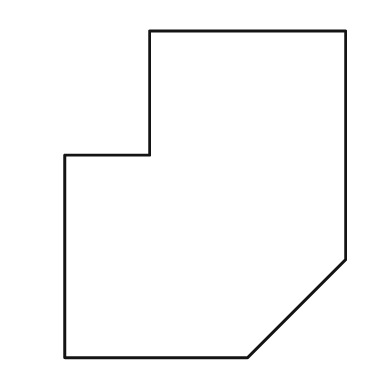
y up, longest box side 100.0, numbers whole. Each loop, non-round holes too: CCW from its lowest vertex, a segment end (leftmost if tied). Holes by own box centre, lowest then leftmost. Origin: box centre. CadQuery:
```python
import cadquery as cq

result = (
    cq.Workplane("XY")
    .moveTo(-43.0, -50.0)
    .lineTo(13.0, -50.0)
    .lineTo(43.0, -20.0)
    .lineTo(43.0, 50.0)
    .lineTo(-17.0, 50.0)
    .lineTo(-17.0, 12.0)
    .lineTo(-43.0, 12.0)
    .close()
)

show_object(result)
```